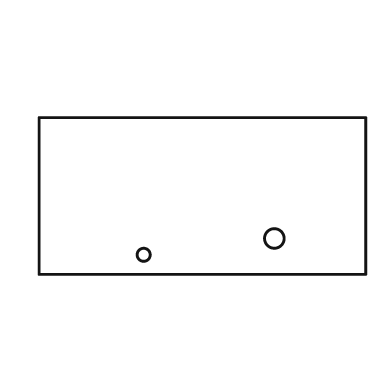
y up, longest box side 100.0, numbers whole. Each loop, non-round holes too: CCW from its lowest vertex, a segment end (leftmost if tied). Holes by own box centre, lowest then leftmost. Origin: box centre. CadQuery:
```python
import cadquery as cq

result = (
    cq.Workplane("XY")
    .moveTo(-50.0, -24.0)
    .lineTo(50.0, -24.0)
    .lineTo(50.0, 24.0)
    .lineTo(-50.0, 24.0)
    .close()
    .moveTo(-18.0, -18.0)
    .circle(2.0)
    .moveTo(22.0, -13.0)
    .circle(3.0)
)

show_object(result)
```